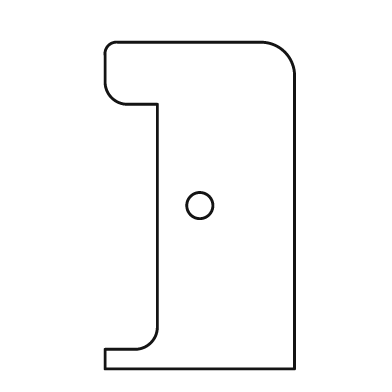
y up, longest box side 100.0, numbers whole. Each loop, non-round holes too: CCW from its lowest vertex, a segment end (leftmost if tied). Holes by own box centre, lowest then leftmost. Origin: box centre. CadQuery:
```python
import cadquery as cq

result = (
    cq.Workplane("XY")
    .moveTo(-29.0, -50.0)
    .lineTo(29.0, -50.0)
    .lineTo(29.0, 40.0)
    .threePointArc((26.0, 47.0), (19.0, 50.0))
    .lineTo(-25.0, 50.0)
    .threePointArc((-28.0, 49.0), (-29.0, 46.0))
    .lineTo(-29.0, 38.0)
    .threePointArc((-27.0, 33.0), (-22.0, 31.0))
    .lineTo(-13.0, 31.0)
    .lineTo(-13.0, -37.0)
    .threePointArc((-15.0, -42.0), (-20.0, -44.0))
    .lineTo(-29.0, -44.0)
    .close()
    .moveTo(0.0, 0.0)
    .circle(4.0)
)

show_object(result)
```